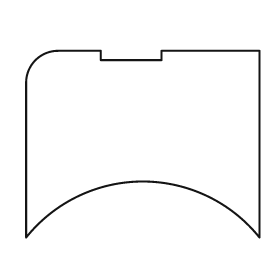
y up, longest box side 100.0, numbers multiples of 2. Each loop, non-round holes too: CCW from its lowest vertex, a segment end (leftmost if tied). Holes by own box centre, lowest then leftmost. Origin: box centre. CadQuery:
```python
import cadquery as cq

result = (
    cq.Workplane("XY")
    .moveTo(-50.0, -40.0)
    .threePointArc((0.0, -16.0), (50.0, -40.0))
    .lineTo(50.0, 40.0)
    .lineTo(8.0, 40.0)
    .lineTo(8.0, 36.0)
    .lineTo(-18.0, 36.0)
    .lineTo(-18.0, 40.0)
    .lineTo(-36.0, 40.0)
    .threePointArc((-46.0, 36.0), (-50.0, 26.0))
    .close()
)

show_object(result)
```